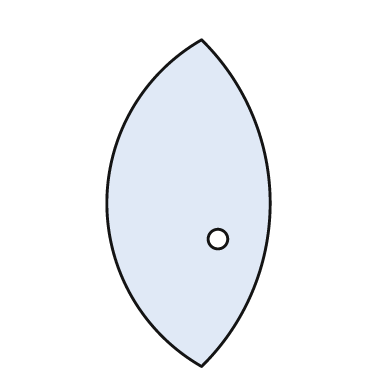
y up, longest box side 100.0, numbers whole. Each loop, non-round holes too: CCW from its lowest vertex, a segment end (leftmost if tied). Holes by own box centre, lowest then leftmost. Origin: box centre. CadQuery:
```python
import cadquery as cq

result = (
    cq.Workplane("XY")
    .moveTo(4.0, -50.0)
    .threePointArc((25.0, 0.0), (4.0, 50.0))
    .threePointArc((-25.0, 0.0), (4.0, -50.0))
    .close()
    .moveTo(9.0, -11.0)
    .circle(3.0)
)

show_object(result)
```